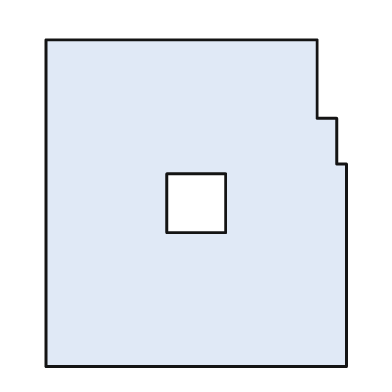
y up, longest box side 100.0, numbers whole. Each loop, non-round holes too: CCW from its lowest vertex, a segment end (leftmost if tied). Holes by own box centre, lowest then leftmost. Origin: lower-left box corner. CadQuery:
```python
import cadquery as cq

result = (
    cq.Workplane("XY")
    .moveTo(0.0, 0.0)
    .lineTo(92.0, 0.0)
    .lineTo(92.0, 62.0)
    .lineTo(89.0, 62.0)
    .lineTo(89.0, 76.0)
    .lineTo(83.0, 76.0)
    .lineTo(83.0, 100.0)
    .lineTo(0.0, 100.0)
    .close()
    .moveTo(37.0, 41.0)
    .lineTo(55.0, 41.0)
    .lineTo(55.0, 59.0)
    .lineTo(37.0, 59.0)
    .close()
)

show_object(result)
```